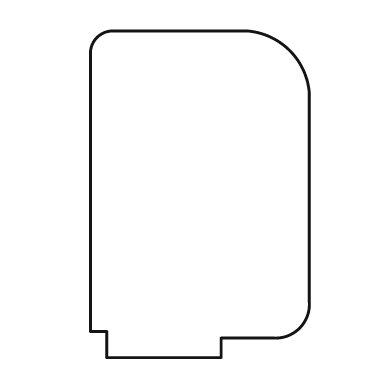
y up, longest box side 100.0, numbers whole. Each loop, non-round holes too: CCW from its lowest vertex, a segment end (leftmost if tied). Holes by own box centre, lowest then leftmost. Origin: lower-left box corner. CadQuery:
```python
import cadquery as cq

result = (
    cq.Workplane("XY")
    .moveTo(5.0, 0.0)
    .lineTo(40.0, 0.0)
    .lineTo(40.0, 6.0)
    .lineTo(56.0, 6.0)
    .threePointArc((64.0, 9.0), (67.0, 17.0))
    .lineTo(67.0, 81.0)
    .threePointArc((61.0, 94.0), (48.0, 100.0))
    .lineTo(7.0, 100.0)
    .threePointArc((2.0, 98.0), (0.0, 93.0))
    .lineTo(0.0, 8.0)
    .lineTo(5.0, 8.0)
    .close()
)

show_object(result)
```